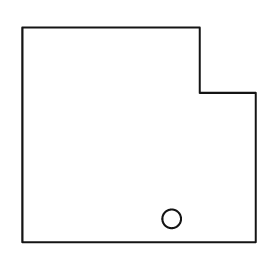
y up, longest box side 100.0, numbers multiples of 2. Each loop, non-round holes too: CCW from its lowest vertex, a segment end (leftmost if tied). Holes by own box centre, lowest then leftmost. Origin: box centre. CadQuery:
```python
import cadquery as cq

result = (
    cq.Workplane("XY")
    .moveTo(-50.0, -46.0)
    .lineTo(50.0, -46.0)
    .lineTo(50.0, 18.0)
    .lineTo(26.0, 18.0)
    .lineTo(26.0, 46.0)
    .lineTo(-50.0, 46.0)
    .close()
    .moveTo(14.0, -36.0)
    .circle(4.0)
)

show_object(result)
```